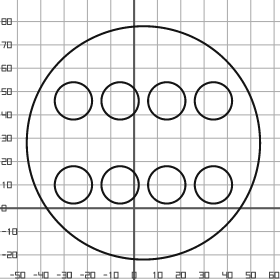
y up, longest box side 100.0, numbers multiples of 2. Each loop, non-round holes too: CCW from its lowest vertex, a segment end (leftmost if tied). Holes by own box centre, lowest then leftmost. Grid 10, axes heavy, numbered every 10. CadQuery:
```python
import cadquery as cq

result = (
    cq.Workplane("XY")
    .moveTo(4.0, 28.0)
    .circle(50.0)
    .moveTo(-26.0, 10.0)
    .circle(8.0)
    .moveTo(-6.0, 10.0)
    .circle(8.0)
    .moveTo(14.0, 10.0)
    .circle(8.0)
    .moveTo(34.0, 10.0)
    .circle(8.0)
    .moveTo(-26.0, 46.0)
    .circle(8.0)
    .moveTo(-6.0, 46.0)
    .circle(8.0)
    .moveTo(14.0, 46.0)
    .circle(8.0)
    .moveTo(34.0, 46.0)
    .circle(8.0)
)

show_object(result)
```